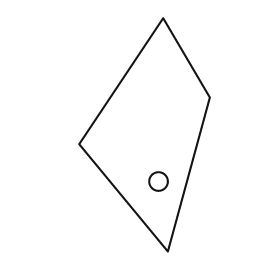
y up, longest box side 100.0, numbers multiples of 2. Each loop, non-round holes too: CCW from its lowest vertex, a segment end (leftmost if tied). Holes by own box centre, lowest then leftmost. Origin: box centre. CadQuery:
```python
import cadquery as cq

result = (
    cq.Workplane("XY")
    .moveTo(10.0, -50.0)
    .lineTo(28.0, 16.0)
    .lineTo(8.0, 50.0)
    .lineTo(-28.0, -4.0)
    .close()
    .moveTo(6.0, -20.0)
    .circle(4.0)
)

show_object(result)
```